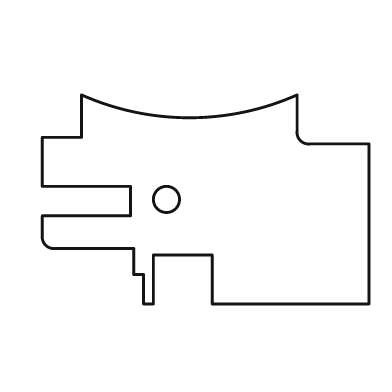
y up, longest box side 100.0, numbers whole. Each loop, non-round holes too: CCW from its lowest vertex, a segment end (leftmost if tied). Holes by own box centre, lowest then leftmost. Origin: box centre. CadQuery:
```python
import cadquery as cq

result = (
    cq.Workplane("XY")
    .moveTo(-19.0, -32.0)
    .lineTo(-16.0, -32.0)
    .lineTo(-16.0, -17.0)
    .lineTo(2.0, -17.0)
    .lineTo(2.0, -32.0)
    .lineTo(50.0, -32.0)
    .lineTo(50.0, 17.0)
    .lineTo(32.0, 17.0)
    .threePointArc((29.0, 18.0), (28.0, 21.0))
    .lineTo(28.0, 32.0)
    .threePointArc((-5.0, 25.0), (-38.0, 32.0))
    .lineTo(-38.0, 19.0)
    .lineTo(-50.0, 19.0)
    .lineTo(-50.0, 4.0)
    .lineTo(-23.0, 4.0)
    .lineTo(-23.0, -5.0)
    .lineTo(-50.0, -5.0)
    .lineTo(-50.0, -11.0)
    .threePointArc((-49.0, -14.0), (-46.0, -15.0))
    .lineTo(-22.0, -15.0)
    .lineTo(-22.0, -23.0)
    .lineTo(-19.0, -23.0)
    .close()
    .moveTo(-12.0, 0.0)
    .circle(4.0)
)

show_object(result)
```